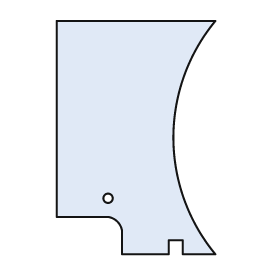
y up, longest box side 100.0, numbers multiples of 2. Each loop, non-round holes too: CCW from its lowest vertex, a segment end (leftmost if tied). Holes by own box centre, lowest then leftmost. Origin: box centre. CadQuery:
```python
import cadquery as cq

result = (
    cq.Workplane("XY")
    .moveTo(-6.0, -50.0)
    .lineTo(14.0, -50.0)
    .lineTo(14.0, -44.0)
    .lineTo(20.0, -44.0)
    .lineTo(20.0, -50.0)
    .lineTo(34.0, -50.0)
    .threePointArc((16.0, 0.0), (34.0, 50.0))
    .lineTo(-34.0, 50.0)
    .lineTo(-34.0, -34.0)
    .lineTo(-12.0, -34.0)
    .threePointArc((-8.0, -36.0), (-6.0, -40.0))
    .close()
    .moveTo(-12.0, -26.0)
    .circle(2.0)
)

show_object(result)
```